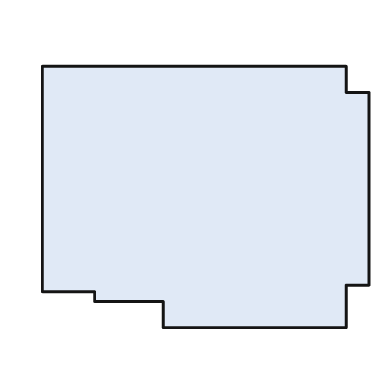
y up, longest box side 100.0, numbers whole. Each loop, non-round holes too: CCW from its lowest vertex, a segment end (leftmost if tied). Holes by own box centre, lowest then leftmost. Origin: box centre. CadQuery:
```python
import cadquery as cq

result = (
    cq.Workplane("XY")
    .moveTo(-13.0, -40.0)
    .lineTo(43.0, -40.0)
    .lineTo(43.0, -27.0)
    .lineTo(50.0, -27.0)
    .lineTo(50.0, 32.0)
    .lineTo(43.0, 32.0)
    .lineTo(43.0, 40.0)
    .lineTo(-50.0, 40.0)
    .lineTo(-50.0, -29.0)
    .lineTo(-34.0, -29.0)
    .lineTo(-34.0, -32.0)
    .lineTo(-13.0, -32.0)
    .close()
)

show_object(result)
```